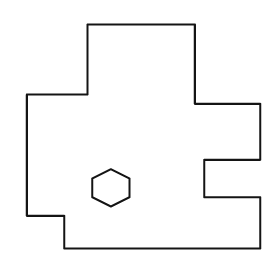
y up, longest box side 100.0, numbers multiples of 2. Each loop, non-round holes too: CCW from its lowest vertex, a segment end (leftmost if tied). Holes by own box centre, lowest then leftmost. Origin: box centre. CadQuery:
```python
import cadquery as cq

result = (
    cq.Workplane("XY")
    .moveTo(-34.0, -48.0)
    .lineTo(50.0, -48.0)
    .lineTo(50.0, -26.0)
    .lineTo(26.0, -26.0)
    .lineTo(26.0, -10.0)
    .lineTo(50.0, -10.0)
    .lineTo(50.0, 14.0)
    .lineTo(22.0, 14.0)
    .lineTo(22.0, 48.0)
    .lineTo(-24.0, 48.0)
    .lineTo(-24.0, 18.0)
    .lineTo(-50.0, 18.0)
    .lineTo(-50.0, -34.0)
    .lineTo(-34.0, -34.0)
    .close()
    .moveTo(-14.0, -30.0)
    .lineTo(-6.0, -26.0)
    .lineTo(-6.0, -18.0)
    .lineTo(-14.0, -14.0)
    .lineTo(-22.0, -18.0)
    .lineTo(-22.0, -26.0)
    .close()
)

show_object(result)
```